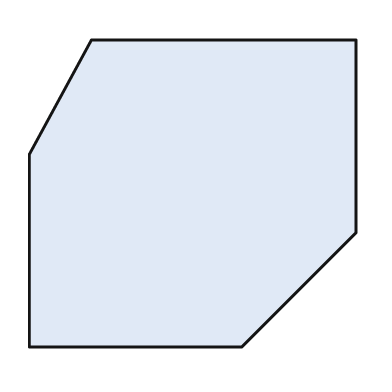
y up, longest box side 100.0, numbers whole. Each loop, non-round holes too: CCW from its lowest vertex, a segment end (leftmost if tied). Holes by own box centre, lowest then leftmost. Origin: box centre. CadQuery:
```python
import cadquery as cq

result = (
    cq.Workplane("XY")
    .moveTo(-50.0, -47.0)
    .lineTo(15.0, -47.0)
    .lineTo(50.0, -12.0)
    .lineTo(50.0, 47.0)
    .lineTo(-31.0, 47.0)
    .lineTo(-50.0, 12.0)
    .close()
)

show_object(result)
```